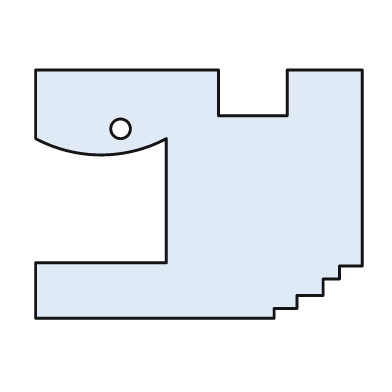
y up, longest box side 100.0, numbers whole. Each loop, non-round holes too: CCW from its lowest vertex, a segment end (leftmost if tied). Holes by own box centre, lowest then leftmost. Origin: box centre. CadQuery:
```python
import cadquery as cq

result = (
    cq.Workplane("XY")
    .moveTo(-50.0, -38.0)
    .lineTo(23.0, -38.0)
    .lineTo(23.0, -35.0)
    .lineTo(30.0, -35.0)
    .lineTo(30.0, -31.0)
    .lineTo(38.0, -31.0)
    .lineTo(38.0, -26.0)
    .lineTo(43.0, -26.0)
    .lineTo(43.0, -22.0)
    .lineTo(50.0, -22.0)
    .lineTo(50.0, 38.0)
    .lineTo(27.0, 38.0)
    .lineTo(27.0, 24.0)
    .lineTo(6.0, 24.0)
    .lineTo(6.0, 38.0)
    .lineTo(-50.0, 38.0)
    .lineTo(-50.0, 17.0)
    .threePointArc((-30.0, 12.0), (-10.0, 17.0))
    .lineTo(-10.0, -21.0)
    .lineTo(-50.0, -21.0)
    .close()
    .moveTo(-24.0, 20.0)
    .circle(3.0)
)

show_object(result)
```